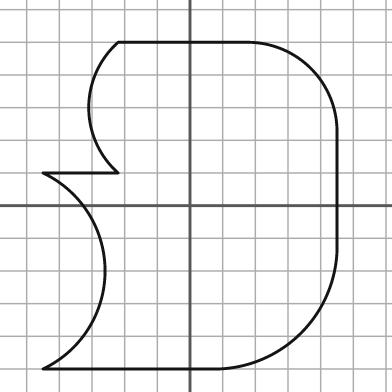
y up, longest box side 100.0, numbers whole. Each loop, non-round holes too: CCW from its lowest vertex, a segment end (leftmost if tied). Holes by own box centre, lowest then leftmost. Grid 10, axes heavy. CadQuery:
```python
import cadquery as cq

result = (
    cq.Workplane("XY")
    .moveTo(-45.0, -50.0)
    .lineTo(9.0, -50.0)
    .threePointArc((34.0, -39.0), (45.0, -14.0))
    .lineTo(45.0, 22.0)
    .threePointArc((37.0, 42.0), (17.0, 50.0))
    .lineTo(-22.0, 50.0)
    .threePointArc((-31.0, 30.0), (-22.0, 10.0))
    .lineTo(-45.0, 10.0)
    .threePointArc((-26.0, -20.0), (-45.0, -50.0))
    .close()
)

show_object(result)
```